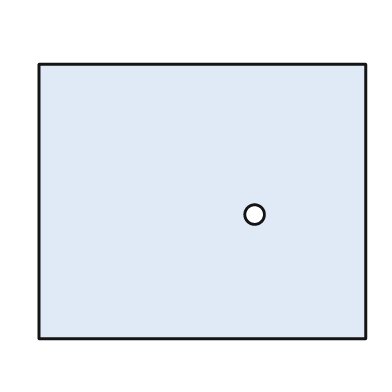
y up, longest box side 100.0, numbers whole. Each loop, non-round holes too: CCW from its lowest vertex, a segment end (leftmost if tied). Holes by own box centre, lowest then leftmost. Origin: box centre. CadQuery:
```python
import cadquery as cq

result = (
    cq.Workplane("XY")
    .moveTo(-50.0, -42.0)
    .lineTo(50.0, -42.0)
    .lineTo(50.0, 42.0)
    .lineTo(-50.0, 42.0)
    .close()
    .moveTo(16.0, -4.0)
    .circle(3.0)
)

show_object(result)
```